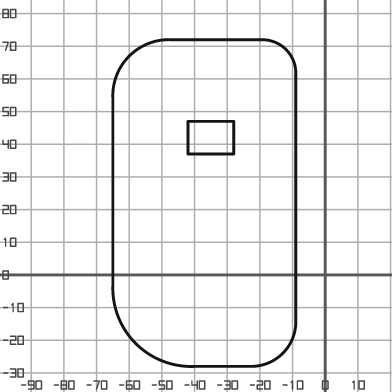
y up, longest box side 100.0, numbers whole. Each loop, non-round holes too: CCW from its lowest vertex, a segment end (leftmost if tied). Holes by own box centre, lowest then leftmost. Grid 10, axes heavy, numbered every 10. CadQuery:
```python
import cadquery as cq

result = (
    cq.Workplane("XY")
    .moveTo(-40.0, -28.0)
    .lineTo(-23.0, -28.0)
    .threePointArc((-13.0, -24.0), (-9.0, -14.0))
    .lineTo(-9.0, 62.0)
    .threePointArc((-12.0, 69.0), (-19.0, 72.0))
    .lineTo(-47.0, 72.0)
    .threePointArc((-60.0, 67.0), (-65.0, 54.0))
    .lineTo(-65.0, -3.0)
    .threePointArc((-58.0, -21.0), (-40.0, -28.0))
    .close()
    .moveTo(-42.0, 37.0)
    .lineTo(-28.0, 37.0)
    .lineTo(-28.0, 47.0)
    .lineTo(-42.0, 47.0)
    .close()
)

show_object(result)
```